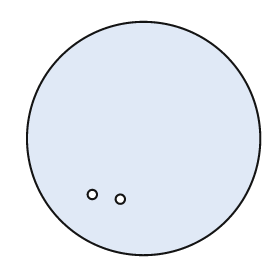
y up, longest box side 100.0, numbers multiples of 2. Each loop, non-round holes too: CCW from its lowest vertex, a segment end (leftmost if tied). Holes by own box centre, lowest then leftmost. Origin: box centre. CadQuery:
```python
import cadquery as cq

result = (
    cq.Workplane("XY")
    .moveTo(0.0, 0.0)
    .circle(50.0)
    .moveTo(-10.0, -26.0)
    .circle(2.0)
    .moveTo(-22.0, -24.0)
    .circle(2.0)
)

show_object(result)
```